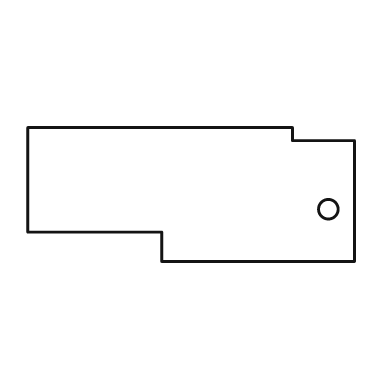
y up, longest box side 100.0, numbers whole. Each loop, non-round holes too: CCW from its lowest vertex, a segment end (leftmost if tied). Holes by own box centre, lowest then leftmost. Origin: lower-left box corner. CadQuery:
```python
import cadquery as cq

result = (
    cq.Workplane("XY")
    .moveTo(41.0, 0.0)
    .lineTo(100.0, 0.0)
    .lineTo(100.0, 37.0)
    .lineTo(81.0, 37.0)
    .lineTo(81.0, 41.0)
    .lineTo(0.0, 41.0)
    .lineTo(0.0, 9.0)
    .lineTo(41.0, 9.0)
    .close()
    .moveTo(92.0, 16.0)
    .circle(3.0)
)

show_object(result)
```